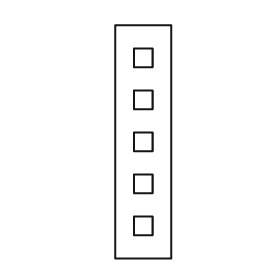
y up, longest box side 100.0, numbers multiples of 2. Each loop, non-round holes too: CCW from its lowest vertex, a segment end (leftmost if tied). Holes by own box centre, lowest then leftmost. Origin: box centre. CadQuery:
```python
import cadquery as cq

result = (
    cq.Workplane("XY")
    .moveTo(-12.0, -50.0)
    .lineTo(12.0, -50.0)
    .lineTo(12.0, 50.0)
    .lineTo(-12.0, 50.0)
    .close()
    .moveTo(-4.0, -40.0)
    .lineTo(4.0, -40.0)
    .lineTo(4.0, -32.0)
    .lineTo(-4.0, -32.0)
    .close()
    .moveTo(-4.0, -22.0)
    .lineTo(4.0, -22.0)
    .lineTo(4.0, -14.0)
    .lineTo(-4.0, -14.0)
    .close()
    .moveTo(-4.0, -4.0)
    .lineTo(4.0, -4.0)
    .lineTo(4.0, 4.0)
    .lineTo(-4.0, 4.0)
    .close()
    .moveTo(-4.0, 14.0)
    .lineTo(4.0, 14.0)
    .lineTo(4.0, 22.0)
    .lineTo(-4.0, 22.0)
    .close()
    .moveTo(-4.0, 32.0)
    .lineTo(4.0, 32.0)
    .lineTo(4.0, 40.0)
    .lineTo(-4.0, 40.0)
    .close()
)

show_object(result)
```